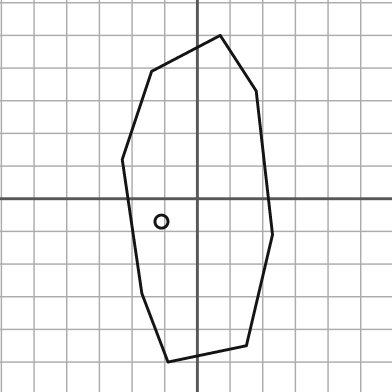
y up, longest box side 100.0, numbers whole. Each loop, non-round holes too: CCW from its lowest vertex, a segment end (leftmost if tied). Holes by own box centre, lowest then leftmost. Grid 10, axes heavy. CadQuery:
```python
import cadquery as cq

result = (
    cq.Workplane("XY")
    .moveTo(-9.0, -50.0)
    .lineTo(15.0, -45.0)
    .lineTo(23.0, -11.0)
    .lineTo(18.0, 33.0)
    .lineTo(7.0, 50.0)
    .lineTo(-14.0, 39.0)
    .lineTo(-23.0, 12.0)
    .lineTo(-17.0, -29.0)
    .close()
    .moveTo(-11.0, -7.0)
    .circle(2.0)
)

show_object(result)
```